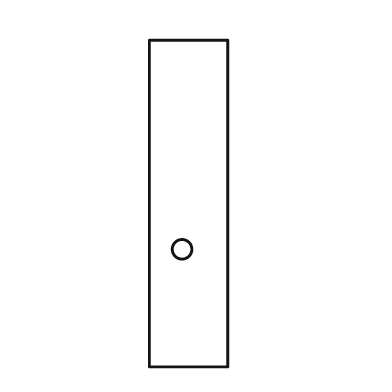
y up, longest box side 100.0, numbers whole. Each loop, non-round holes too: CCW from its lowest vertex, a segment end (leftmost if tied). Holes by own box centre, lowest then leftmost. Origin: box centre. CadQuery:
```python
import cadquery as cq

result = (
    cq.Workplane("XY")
    .moveTo(-12.0, -50.0)
    .lineTo(12.0, -50.0)
    .lineTo(12.0, 50.0)
    .lineTo(-12.0, 50.0)
    .close()
    .moveTo(-2.0, -14.0)
    .circle(3.0)
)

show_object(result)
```